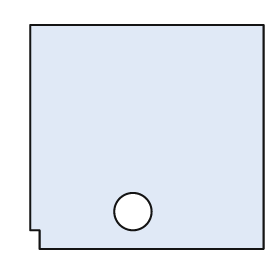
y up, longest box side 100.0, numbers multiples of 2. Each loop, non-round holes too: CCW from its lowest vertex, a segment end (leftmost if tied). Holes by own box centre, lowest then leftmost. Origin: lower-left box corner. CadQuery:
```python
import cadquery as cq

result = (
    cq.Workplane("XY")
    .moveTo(4.0, 0.0)
    .lineTo(100.0, 0.0)
    .lineTo(100.0, 96.0)
    .lineTo(0.0, 96.0)
    .lineTo(0.0, 8.0)
    .lineTo(4.0, 8.0)
    .close()
    .moveTo(44.0, 16.0)
    .circle(8.0)
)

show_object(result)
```